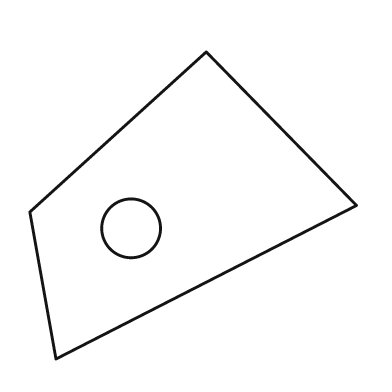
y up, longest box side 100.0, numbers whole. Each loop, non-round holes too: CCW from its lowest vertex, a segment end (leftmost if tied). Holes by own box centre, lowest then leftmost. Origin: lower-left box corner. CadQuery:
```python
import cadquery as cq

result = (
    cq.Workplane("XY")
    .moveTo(8.0, 0.0)
    .lineTo(100.0, 47.0)
    .lineTo(54.0, 94.0)
    .lineTo(0.0, 45.0)
    .close()
    .moveTo(31.0, 40.0)
    .circle(9.0)
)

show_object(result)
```